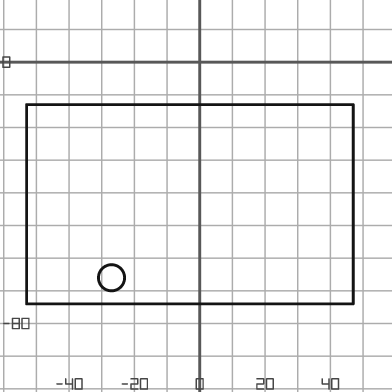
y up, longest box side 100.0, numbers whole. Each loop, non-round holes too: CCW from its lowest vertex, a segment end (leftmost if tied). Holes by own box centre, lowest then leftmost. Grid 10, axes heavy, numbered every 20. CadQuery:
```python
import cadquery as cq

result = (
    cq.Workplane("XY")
    .moveTo(-53.0, -74.0)
    .lineTo(47.0, -74.0)
    .lineTo(47.0, -13.0)
    .lineTo(-53.0, -13.0)
    .close()
    .moveTo(-27.0, -66.0)
    .circle(4.0)
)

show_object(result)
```